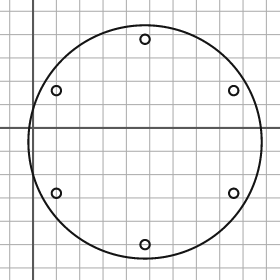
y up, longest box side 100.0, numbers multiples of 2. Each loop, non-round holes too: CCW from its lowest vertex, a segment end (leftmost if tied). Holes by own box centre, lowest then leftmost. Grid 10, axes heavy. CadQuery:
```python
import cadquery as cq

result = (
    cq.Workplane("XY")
    .moveTo(48.0, -6.0)
    .circle(50.0)
    .moveTo(48.0, -50.0)
    .circle(2.0)
    .moveTo(10.0, -28.0)
    .circle(2.0)
    .moveTo(86.0, -28.0)
    .circle(2.0)
    .moveTo(10.0, 16.0)
    .circle(2.0)
    .moveTo(86.0, 16.0)
    .circle(2.0)
    .moveTo(48.0, 38.0)
    .circle(2.0)
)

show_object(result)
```